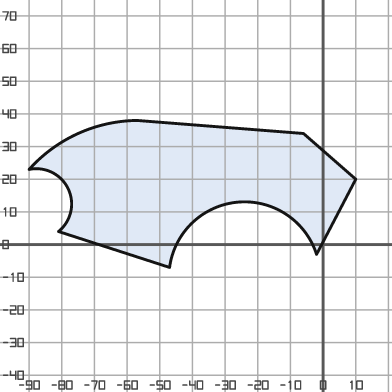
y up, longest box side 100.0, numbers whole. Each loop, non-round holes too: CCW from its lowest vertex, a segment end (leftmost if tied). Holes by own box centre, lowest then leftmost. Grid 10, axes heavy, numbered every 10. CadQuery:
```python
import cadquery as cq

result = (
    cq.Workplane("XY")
    .moveTo(-47.0, -7.0)
    .threePointArc((-26.0, 13.0), (-2.0, -3.0))
    .lineTo(10.0, 20.0)
    .lineTo(-6.0, 34.0)
    .lineTo(-57.0, 38.0)
    .threePointArc((-75.0, 34.0), (-90.0, 23.0))
    .threePointArc((-78.0, 17.0), (-81.0, 4.0))
    .close()
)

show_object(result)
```